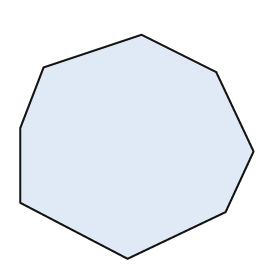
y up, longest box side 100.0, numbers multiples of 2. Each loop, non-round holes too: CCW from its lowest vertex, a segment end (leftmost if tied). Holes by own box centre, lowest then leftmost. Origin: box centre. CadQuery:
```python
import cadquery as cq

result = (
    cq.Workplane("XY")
    .moveTo(-4.0, -48.0)
    .lineTo(38.0, -28.0)
    .lineTo(50.0, -2.0)
    .lineTo(34.0, 32.0)
    .lineTo(2.0, 48.0)
    .lineTo(-40.0, 34.0)
    .lineTo(-50.0, 8.0)
    .lineTo(-50.0, -24.0)
    .close()
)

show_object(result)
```